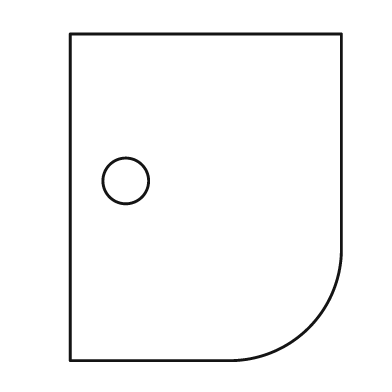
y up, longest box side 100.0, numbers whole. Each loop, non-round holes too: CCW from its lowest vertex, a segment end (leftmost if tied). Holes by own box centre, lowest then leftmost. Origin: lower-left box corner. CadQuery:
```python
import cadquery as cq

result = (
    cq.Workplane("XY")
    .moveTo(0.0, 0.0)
    .lineTo(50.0, 0.0)
    .threePointArc((73.0, 10.0), (83.0, 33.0))
    .lineTo(83.0, 100.0)
    .lineTo(0.0, 100.0)
    .close()
    .moveTo(17.0, 55.0)
    .circle(7.0)
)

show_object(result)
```